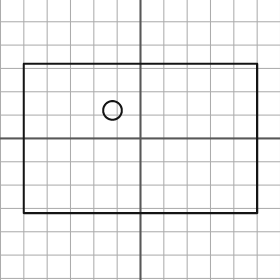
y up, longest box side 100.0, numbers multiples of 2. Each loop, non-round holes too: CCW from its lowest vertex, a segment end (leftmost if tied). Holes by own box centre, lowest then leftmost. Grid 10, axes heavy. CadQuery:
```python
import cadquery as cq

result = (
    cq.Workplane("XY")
    .moveTo(-50.0, -32.0)
    .lineTo(50.0, -32.0)
    .lineTo(50.0, 32.0)
    .lineTo(-50.0, 32.0)
    .close()
    .moveTo(-12.0, 12.0)
    .circle(4.0)
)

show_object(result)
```